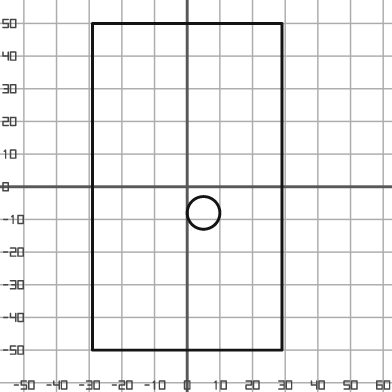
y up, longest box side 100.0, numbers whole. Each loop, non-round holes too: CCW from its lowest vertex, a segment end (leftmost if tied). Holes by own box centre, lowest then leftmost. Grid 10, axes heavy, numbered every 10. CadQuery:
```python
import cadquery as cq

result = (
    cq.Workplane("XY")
    .moveTo(-29.0, -50.0)
    .lineTo(29.0, -50.0)
    .lineTo(29.0, 50.0)
    .lineTo(-29.0, 50.0)
    .close()
    .moveTo(5.0, -8.0)
    .circle(5.0)
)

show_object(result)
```